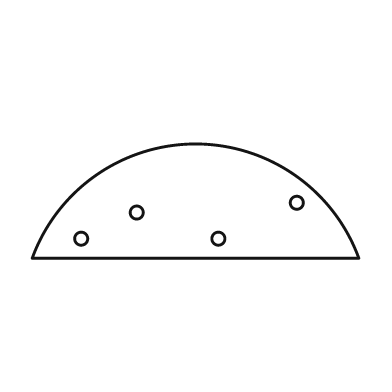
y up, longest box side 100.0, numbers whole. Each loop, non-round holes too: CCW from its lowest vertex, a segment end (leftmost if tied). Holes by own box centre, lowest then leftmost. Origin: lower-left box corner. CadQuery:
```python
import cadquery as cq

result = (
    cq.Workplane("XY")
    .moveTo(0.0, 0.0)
    .lineTo(100.0, 0.0)
    .threePointArc((50.0, 35.0), (0.0, 0.0))
    .close()
    .moveTo(15.0, 6.0)
    .circle(2.0)
    .moveTo(57.0, 6.0)
    .circle(2.0)
    .moveTo(32.0, 14.0)
    .circle(2.0)
    .moveTo(81.0, 17.0)
    .circle(2.0)
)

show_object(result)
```